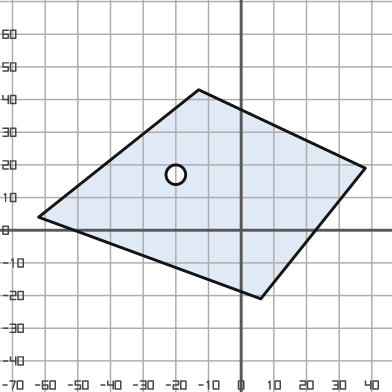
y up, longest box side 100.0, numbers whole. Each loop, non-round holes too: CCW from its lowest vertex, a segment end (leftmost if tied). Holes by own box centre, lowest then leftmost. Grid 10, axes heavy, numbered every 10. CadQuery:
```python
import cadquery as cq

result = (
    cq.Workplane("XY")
    .moveTo(6.0, -21.0)
    .lineTo(38.0, 19.0)
    .lineTo(-13.0, 43.0)
    .lineTo(-62.0, 4.0)
    .close()
    .moveTo(-20.0, 17.0)
    .circle(3.0)
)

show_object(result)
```